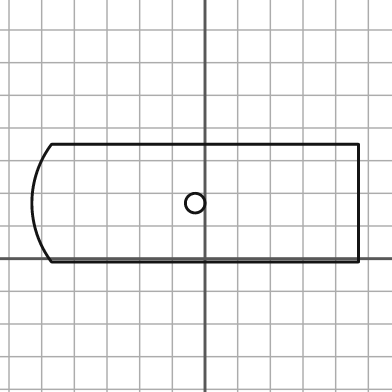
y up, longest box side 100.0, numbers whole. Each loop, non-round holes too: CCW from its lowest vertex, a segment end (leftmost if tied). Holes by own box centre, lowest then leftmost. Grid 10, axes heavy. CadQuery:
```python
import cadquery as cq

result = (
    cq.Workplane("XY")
    .moveTo(-47.0, -1.0)
    .lineTo(47.0, -1.0)
    .lineTo(47.0, 35.0)
    .lineTo(-47.0, 35.0)
    .threePointArc((-53.0, 17.0), (-47.0, -1.0))
    .close()
    .moveTo(-3.0, 17.0)
    .circle(3.0)
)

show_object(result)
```